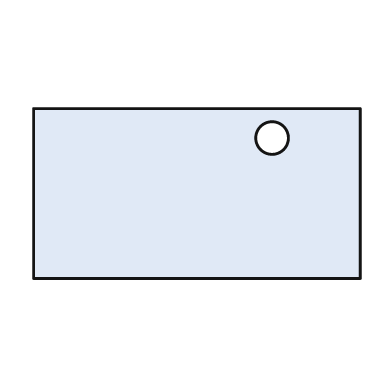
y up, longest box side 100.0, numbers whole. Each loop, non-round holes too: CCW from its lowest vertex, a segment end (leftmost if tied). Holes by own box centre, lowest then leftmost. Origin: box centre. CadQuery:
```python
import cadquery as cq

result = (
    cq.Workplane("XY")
    .moveTo(-50.0, -26.0)
    .lineTo(50.0, -26.0)
    .lineTo(50.0, 26.0)
    .lineTo(-50.0, 26.0)
    .close()
    .moveTo(23.0, 17.0)
    .circle(5.0)
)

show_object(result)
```